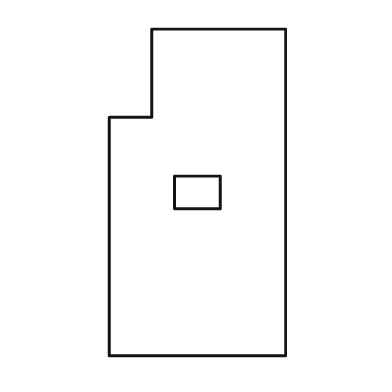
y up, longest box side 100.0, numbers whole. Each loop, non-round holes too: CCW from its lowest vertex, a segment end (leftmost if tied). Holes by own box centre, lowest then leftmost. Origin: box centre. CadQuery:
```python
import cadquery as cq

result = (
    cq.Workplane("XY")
    .moveTo(-27.0, -50.0)
    .lineTo(27.0, -50.0)
    .lineTo(27.0, 50.0)
    .lineTo(-14.0, 50.0)
    .lineTo(-14.0, 23.0)
    .lineTo(-27.0, 23.0)
    .close()
    .moveTo(-7.0, -5.0)
    .lineTo(7.0, -5.0)
    .lineTo(7.0, 5.0)
    .lineTo(-7.0, 5.0)
    .close()
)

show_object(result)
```